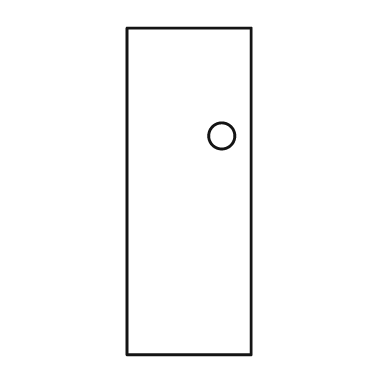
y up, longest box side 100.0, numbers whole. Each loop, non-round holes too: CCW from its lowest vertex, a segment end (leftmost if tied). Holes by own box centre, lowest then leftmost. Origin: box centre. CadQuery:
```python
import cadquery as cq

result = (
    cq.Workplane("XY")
    .moveTo(-19.0, -50.0)
    .lineTo(19.0, -50.0)
    .lineTo(19.0, 50.0)
    .lineTo(-19.0, 50.0)
    .close()
    .moveTo(10.0, 17.0)
    .circle(4.0)
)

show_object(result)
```